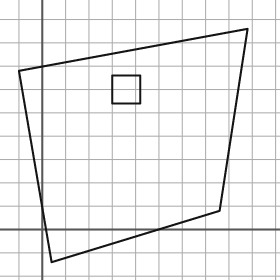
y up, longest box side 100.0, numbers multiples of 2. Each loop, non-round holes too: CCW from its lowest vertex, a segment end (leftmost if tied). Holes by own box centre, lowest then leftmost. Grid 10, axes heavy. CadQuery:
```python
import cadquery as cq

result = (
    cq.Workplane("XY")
    .moveTo(4.0, -14.0)
    .lineTo(76.0, 8.0)
    .lineTo(88.0, 86.0)
    .lineTo(-10.0, 68.0)
    .close()
    .moveTo(30.0, 54.0)
    .lineTo(42.0, 54.0)
    .lineTo(42.0, 66.0)
    .lineTo(30.0, 66.0)
    .close()
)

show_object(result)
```